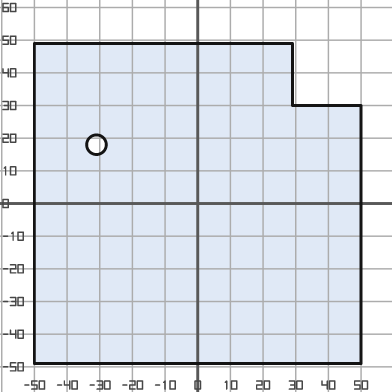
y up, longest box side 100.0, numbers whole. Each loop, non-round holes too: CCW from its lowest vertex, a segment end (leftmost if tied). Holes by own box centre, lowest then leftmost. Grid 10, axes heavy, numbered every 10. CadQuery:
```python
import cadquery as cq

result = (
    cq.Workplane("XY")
    .moveTo(-50.0, -49.0)
    .lineTo(50.0, -49.0)
    .lineTo(50.0, 30.0)
    .lineTo(29.0, 30.0)
    .lineTo(29.0, 49.0)
    .lineTo(-50.0, 49.0)
    .close()
    .moveTo(-31.0, 18.0)
    .circle(3.0)
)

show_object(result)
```